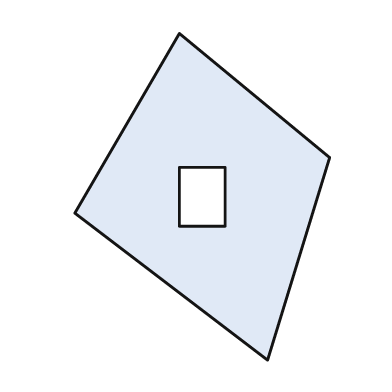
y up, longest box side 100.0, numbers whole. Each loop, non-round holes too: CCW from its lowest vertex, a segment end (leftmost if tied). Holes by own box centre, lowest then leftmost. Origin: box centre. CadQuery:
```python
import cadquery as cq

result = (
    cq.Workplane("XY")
    .moveTo(20.0, -50.0)
    .lineTo(39.0, 12.0)
    .lineTo(-7.0, 50.0)
    .lineTo(-39.0, -5.0)
    .close()
    .moveTo(-7.0, -9.0)
    .lineTo(7.0, -9.0)
    .lineTo(7.0, 9.0)
    .lineTo(-7.0, 9.0)
    .close()
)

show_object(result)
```